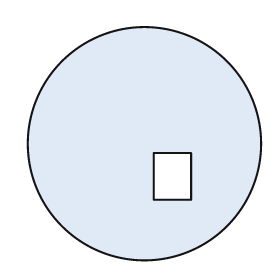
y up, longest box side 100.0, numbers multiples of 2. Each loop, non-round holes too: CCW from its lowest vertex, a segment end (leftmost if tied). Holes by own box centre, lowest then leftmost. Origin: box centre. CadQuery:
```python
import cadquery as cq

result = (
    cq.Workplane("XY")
    .moveTo(0.0, 0.0)
    .circle(50.0)
    .moveTo(4.0, -24.0)
    .lineTo(20.0, -24.0)
    .lineTo(20.0, -4.0)
    .lineTo(4.0, -4.0)
    .close()
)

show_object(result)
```